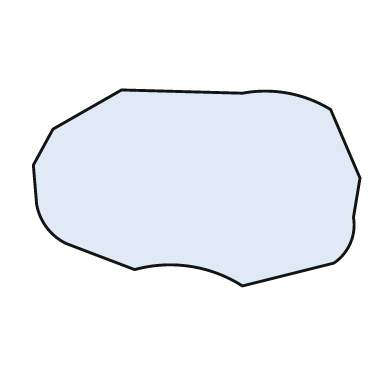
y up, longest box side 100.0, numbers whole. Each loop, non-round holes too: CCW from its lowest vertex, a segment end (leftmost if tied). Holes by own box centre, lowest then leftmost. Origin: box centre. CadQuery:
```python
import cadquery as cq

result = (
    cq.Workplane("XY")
    .moveTo(14.0, -30.0)
    .lineTo(42.0, -23.0)
    .threePointArc((47.0, -17.0), (48.0, -9.0))
    .lineTo(50.0, 3.0)
    .lineTo(41.0, 24.0)
    .threePointArc((28.0, 29.0), (14.0, 29.0))
    .lineTo(-23.0, 30.0)
    .lineTo(-44.0, 18.0)
    .lineTo(-50.0, 7.0)
    .lineTo(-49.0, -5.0)
    .threePointArc((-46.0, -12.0), (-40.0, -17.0))
    .lineTo(-19.0, -25.0)
    .threePointArc((-2.0, -24.0), (14.0, -30.0))
    .close()
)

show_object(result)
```